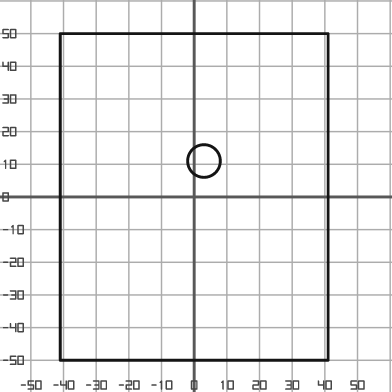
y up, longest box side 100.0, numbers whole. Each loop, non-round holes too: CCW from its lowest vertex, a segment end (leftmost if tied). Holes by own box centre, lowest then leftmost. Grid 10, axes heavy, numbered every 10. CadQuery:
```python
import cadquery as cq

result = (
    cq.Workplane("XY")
    .moveTo(-41.0, -50.0)
    .lineTo(41.0, -50.0)
    .lineTo(41.0, 50.0)
    .lineTo(-41.0, 50.0)
    .close()
    .moveTo(3.0, 11.0)
    .circle(5.0)
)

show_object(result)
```